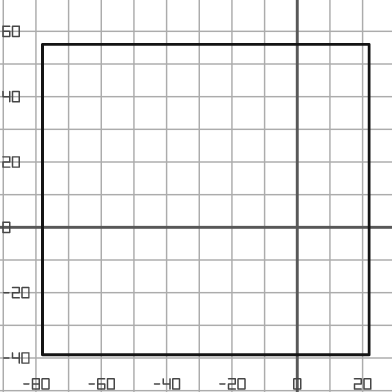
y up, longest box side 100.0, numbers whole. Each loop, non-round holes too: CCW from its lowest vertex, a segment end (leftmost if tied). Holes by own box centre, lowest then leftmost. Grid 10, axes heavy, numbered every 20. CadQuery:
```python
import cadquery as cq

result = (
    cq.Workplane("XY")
    .moveTo(-78.0, -39.0)
    .lineTo(22.0, -39.0)
    .lineTo(22.0, 56.0)
    .lineTo(-78.0, 56.0)
    .close()
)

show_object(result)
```